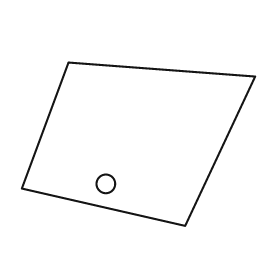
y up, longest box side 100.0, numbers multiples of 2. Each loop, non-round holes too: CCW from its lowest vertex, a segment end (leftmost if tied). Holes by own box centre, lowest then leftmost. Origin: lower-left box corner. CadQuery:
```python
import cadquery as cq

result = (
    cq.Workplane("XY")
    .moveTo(70.0, 0.0)
    .lineTo(100.0, 64.0)
    .lineTo(20.0, 70.0)
    .lineTo(0.0, 16.0)
    .close()
    .moveTo(36.0, 18.0)
    .circle(4.0)
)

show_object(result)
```